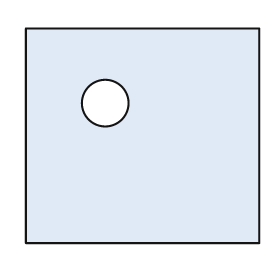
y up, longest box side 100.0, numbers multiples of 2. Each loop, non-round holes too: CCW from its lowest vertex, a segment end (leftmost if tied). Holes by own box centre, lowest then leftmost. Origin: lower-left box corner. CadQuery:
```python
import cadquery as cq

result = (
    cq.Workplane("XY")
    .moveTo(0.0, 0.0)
    .lineTo(100.0, 0.0)
    .lineTo(100.0, 92.0)
    .lineTo(0.0, 92.0)
    .close()
    .moveTo(34.0, 60.0)
    .circle(10.0)
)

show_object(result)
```